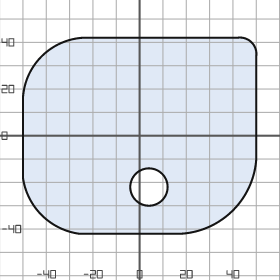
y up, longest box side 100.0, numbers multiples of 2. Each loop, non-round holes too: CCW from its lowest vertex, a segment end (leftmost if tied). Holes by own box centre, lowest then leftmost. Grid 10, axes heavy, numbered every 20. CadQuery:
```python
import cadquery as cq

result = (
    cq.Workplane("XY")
    .moveTo(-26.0, -42.0)
    .lineTo(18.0, -42.0)
    .threePointArc((40.0, -32.0), (50.0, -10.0))
    .lineTo(50.0, 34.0)
    .threePointArc((48.0, 40.0), (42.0, 42.0))
    .lineTo(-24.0, 42.0)
    .threePointArc((-42.0, 34.0), (-50.0, 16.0))
    .lineTo(-50.0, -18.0)
    .threePointArc((-42.0, -34.0), (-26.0, -42.0))
    .close()
    .moveTo(4.0, -22.0)
    .circle(8.0)
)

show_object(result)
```